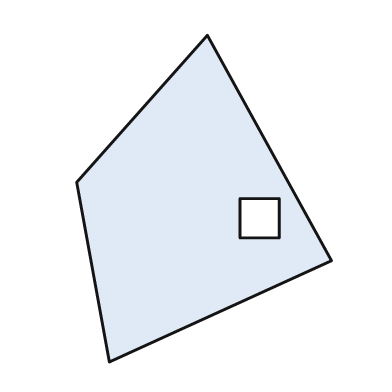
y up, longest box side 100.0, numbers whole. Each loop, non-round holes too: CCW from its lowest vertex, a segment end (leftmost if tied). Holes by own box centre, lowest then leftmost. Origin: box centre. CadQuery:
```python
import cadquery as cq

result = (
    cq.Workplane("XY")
    .moveTo(-29.0, -50.0)
    .lineTo(39.0, -19.0)
    .lineTo(1.0, 50.0)
    .lineTo(-39.0, 5.0)
    .close()
    .moveTo(11.0, -12.0)
    .lineTo(23.0, -12.0)
    .lineTo(23.0, 0.0)
    .lineTo(11.0, 0.0)
    .close()
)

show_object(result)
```